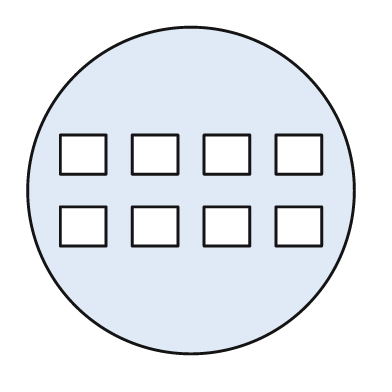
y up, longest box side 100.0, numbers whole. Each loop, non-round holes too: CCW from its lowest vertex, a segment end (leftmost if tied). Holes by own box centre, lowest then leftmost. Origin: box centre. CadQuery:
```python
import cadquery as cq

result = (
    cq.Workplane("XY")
    .moveTo(0.0, 0.0)
    .circle(50.0)
    .moveTo(-40.0, -17.0)
    .lineTo(-26.0, -17.0)
    .lineTo(-26.0, -5.0)
    .lineTo(-40.0, -5.0)
    .close()
    .moveTo(-18.0, -17.0)
    .lineTo(-4.0, -17.0)
    .lineTo(-4.0, -5.0)
    .lineTo(-18.0, -5.0)
    .close()
    .moveTo(4.0, -17.0)
    .lineTo(18.0, -17.0)
    .lineTo(18.0, -5.0)
    .lineTo(4.0, -5.0)
    .close()
    .moveTo(26.0, -17.0)
    .lineTo(40.0, -17.0)
    .lineTo(40.0, -5.0)
    .lineTo(26.0, -5.0)
    .close()
    .moveTo(-40.0, 5.0)
    .lineTo(-26.0, 5.0)
    .lineTo(-26.0, 17.0)
    .lineTo(-40.0, 17.0)
    .close()
    .moveTo(-18.0, 5.0)
    .lineTo(-4.0, 5.0)
    .lineTo(-4.0, 17.0)
    .lineTo(-18.0, 17.0)
    .close()
    .moveTo(4.0, 5.0)
    .lineTo(18.0, 5.0)
    .lineTo(18.0, 17.0)
    .lineTo(4.0, 17.0)
    .close()
    .moveTo(26.0, 5.0)
    .lineTo(40.0, 5.0)
    .lineTo(40.0, 17.0)
    .lineTo(26.0, 17.0)
    .close()
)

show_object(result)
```